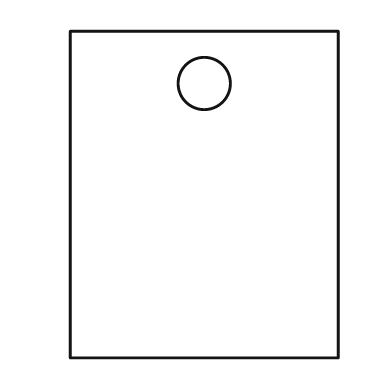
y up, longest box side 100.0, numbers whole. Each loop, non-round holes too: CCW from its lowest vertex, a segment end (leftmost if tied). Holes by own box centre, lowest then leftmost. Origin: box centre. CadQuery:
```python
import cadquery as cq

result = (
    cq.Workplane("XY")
    .moveTo(-41.0, -50.0)
    .lineTo(41.0, -50.0)
    .lineTo(41.0, 50.0)
    .lineTo(-41.0, 50.0)
    .close()
    .moveTo(0.0, 34.0)
    .circle(8.0)
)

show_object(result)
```